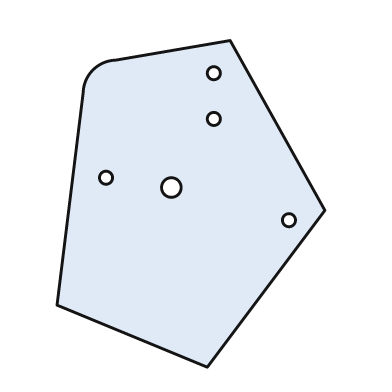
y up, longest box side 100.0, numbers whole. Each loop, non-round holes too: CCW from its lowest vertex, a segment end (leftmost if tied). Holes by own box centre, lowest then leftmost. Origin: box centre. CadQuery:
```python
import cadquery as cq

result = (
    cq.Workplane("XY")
    .moveTo(5.0, -50.0)
    .lineTo(41.0, -2.0)
    .lineTo(12.0, 50.0)
    .lineTo(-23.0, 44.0)
    .threePointArc((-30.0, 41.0), (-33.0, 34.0))
    .lineTo(-41.0, -31.0)
    .close()
    .moveTo(30.0, -5.0)
    .circle(2.0)
    .moveTo(-6.0, 5.0)
    .circle(3.0)
    .moveTo(-26.0, 8.0)
    .circle(2.0)
    .moveTo(7.0, 26.0)
    .circle(2.0)
    .moveTo(7.0, 40.0)
    .circle(2.0)
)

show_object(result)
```